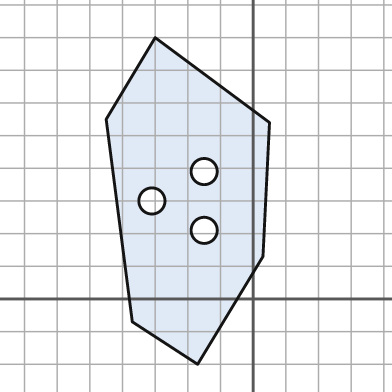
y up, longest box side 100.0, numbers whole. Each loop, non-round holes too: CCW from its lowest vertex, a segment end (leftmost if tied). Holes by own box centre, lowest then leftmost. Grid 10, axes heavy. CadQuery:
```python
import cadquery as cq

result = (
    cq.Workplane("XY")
    .moveTo(-17.0, -20.0)
    .lineTo(3.0, 13.0)
    .lineTo(5.0, 54.0)
    .lineTo(-30.0, 80.0)
    .lineTo(-45.0, 55.0)
    .lineTo(-37.0, -7.0)
    .close()
    .moveTo(-15.0, 21.0)
    .circle(4.0)
    .moveTo(-31.0, 30.0)
    .circle(4.0)
    .moveTo(-15.0, 39.0)
    .circle(4.0)
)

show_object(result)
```